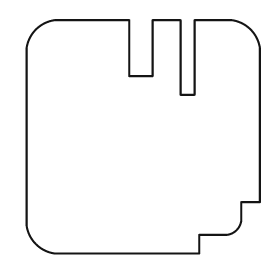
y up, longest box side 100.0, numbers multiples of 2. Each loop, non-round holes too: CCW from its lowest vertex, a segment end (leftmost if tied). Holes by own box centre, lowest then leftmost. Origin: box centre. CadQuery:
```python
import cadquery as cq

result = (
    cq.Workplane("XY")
    .moveTo(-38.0, -50.0)
    .lineTo(24.0, -50.0)
    .lineTo(24.0, -42.0)
    .lineTo(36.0, -42.0)
    .threePointArc((40.0, -40.0), (42.0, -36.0))
    .lineTo(42.0, -28.0)
    .lineTo(50.0, -28.0)
    .lineTo(50.0, 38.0)
    .threePointArc((46.0, 46.0), (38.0, 50.0))
    .lineTo(22.0, 50.0)
    .lineTo(22.0, 18.0)
    .lineTo(16.0, 18.0)
    .lineTo(16.0, 50.0)
    .lineTo(4.0, 50.0)
    .lineTo(4.0, 26.0)
    .lineTo(-6.0, 26.0)
    .lineTo(-6.0, 50.0)
    .lineTo(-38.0, 50.0)
    .threePointArc((-46.0, 46.0), (-50.0, 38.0))
    .lineTo(-50.0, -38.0)
    .threePointArc((-46.0, -46.0), (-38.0, -50.0))
    .close()
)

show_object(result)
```